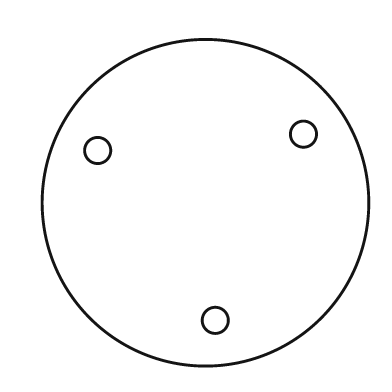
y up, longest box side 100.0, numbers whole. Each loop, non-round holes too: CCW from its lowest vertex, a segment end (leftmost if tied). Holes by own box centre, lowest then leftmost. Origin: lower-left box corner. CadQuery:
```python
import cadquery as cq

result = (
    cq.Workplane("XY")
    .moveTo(50.0, 50.0)
    .circle(50.0)
    .moveTo(53.0, 14.0)
    .circle(4.0)
    .moveTo(17.0, 66.0)
    .circle(4.0)
    .moveTo(80.0, 71.0)
    .circle(4.0)
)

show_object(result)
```